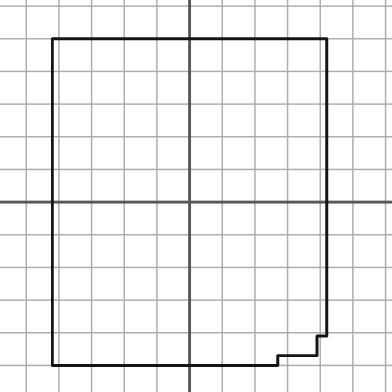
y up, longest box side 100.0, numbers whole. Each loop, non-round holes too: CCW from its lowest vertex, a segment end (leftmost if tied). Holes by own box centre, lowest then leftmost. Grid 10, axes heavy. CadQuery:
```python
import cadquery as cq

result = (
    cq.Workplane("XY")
    .moveTo(-42.0, -50.0)
    .lineTo(27.0, -50.0)
    .lineTo(27.0, -47.0)
    .lineTo(39.0, -47.0)
    .lineTo(39.0, -41.0)
    .lineTo(42.0, -41.0)
    .lineTo(42.0, 50.0)
    .lineTo(-42.0, 50.0)
    .close()
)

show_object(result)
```